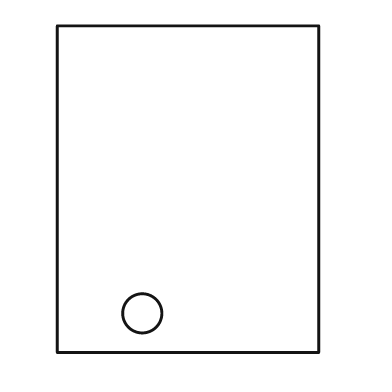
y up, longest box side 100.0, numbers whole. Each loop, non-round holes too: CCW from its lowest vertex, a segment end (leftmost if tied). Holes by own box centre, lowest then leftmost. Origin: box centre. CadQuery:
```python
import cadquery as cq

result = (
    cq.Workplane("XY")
    .moveTo(-40.0, -50.0)
    .lineTo(40.0, -50.0)
    .lineTo(40.0, 50.0)
    .lineTo(-40.0, 50.0)
    .close()
    .moveTo(-14.0, -38.0)
    .circle(6.0)
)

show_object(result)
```